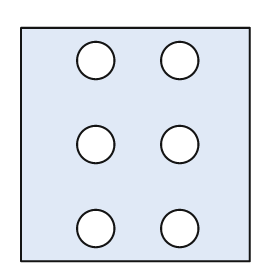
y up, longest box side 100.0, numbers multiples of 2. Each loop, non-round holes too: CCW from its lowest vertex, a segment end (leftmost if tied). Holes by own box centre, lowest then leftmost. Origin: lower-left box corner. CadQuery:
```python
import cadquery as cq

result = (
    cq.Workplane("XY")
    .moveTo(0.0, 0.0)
    .lineTo(98.0, 0.0)
    .lineTo(98.0, 100.0)
    .lineTo(0.0, 100.0)
    .close()
    .moveTo(32.0, 14.0)
    .circle(8.0)
    .moveTo(68.0, 14.0)
    .circle(8.0)
    .moveTo(32.0, 50.0)
    .circle(8.0)
    .moveTo(68.0, 50.0)
    .circle(8.0)
    .moveTo(32.0, 86.0)
    .circle(8.0)
    .moveTo(68.0, 86.0)
    .circle(8.0)
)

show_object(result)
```